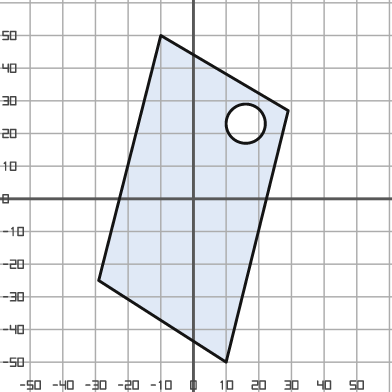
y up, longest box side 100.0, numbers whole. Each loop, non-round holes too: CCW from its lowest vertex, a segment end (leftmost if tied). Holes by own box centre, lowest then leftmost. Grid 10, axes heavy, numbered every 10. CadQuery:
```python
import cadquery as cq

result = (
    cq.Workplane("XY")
    .moveTo(10.0, -50.0)
    .lineTo(29.0, 27.0)
    .lineTo(-10.0, 50.0)
    .lineTo(-29.0, -25.0)
    .close()
    .moveTo(16.0, 23.0)
    .circle(6.0)
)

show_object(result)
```